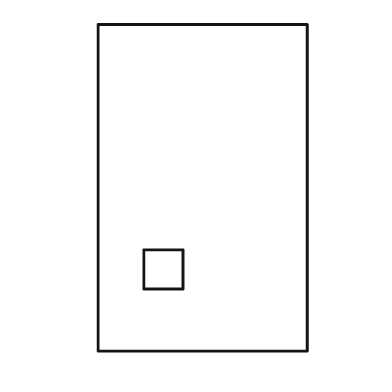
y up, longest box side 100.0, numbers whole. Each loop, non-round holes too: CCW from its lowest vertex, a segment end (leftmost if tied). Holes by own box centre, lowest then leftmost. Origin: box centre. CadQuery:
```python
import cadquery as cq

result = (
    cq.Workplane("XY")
    .moveTo(-32.0, -50.0)
    .lineTo(32.0, -50.0)
    .lineTo(32.0, 50.0)
    .lineTo(-32.0, 50.0)
    .close()
    .moveTo(-18.0, -31.0)
    .lineTo(-6.0, -31.0)
    .lineTo(-6.0, -19.0)
    .lineTo(-18.0, -19.0)
    .close()
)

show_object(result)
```